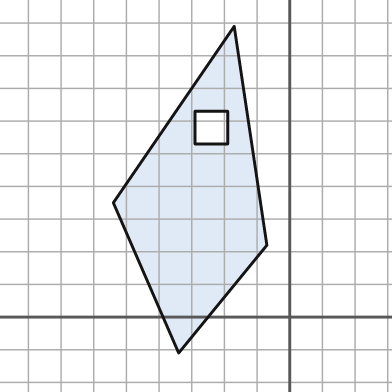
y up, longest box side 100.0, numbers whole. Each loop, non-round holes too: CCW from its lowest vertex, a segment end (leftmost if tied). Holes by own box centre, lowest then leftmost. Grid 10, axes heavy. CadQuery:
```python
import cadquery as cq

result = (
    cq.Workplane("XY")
    .moveTo(-34.0, -11.0)
    .lineTo(-7.0, 22.0)
    .lineTo(-17.0, 89.0)
    .lineTo(-54.0, 35.0)
    .close()
    .moveTo(-29.0, 53.0)
    .lineTo(-19.0, 53.0)
    .lineTo(-19.0, 63.0)
    .lineTo(-29.0, 63.0)
    .close()
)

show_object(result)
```